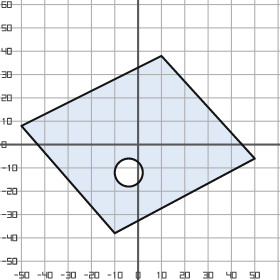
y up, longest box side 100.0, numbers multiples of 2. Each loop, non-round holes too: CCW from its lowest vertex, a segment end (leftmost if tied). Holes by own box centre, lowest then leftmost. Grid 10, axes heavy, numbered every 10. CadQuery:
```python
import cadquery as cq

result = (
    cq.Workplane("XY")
    .moveTo(-10.0, -38.0)
    .lineTo(50.0, -6.0)
    .lineTo(10.0, 38.0)
    .lineTo(-50.0, 8.0)
    .close()
    .moveTo(-4.0, -12.0)
    .circle(6.0)
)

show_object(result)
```